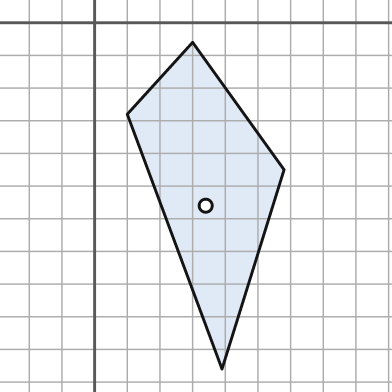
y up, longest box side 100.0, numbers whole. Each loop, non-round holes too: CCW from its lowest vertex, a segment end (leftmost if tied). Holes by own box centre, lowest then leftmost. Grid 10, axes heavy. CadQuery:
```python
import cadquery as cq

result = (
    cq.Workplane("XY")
    .moveTo(39.0, -106.0)
    .lineTo(58.0, -45.0)
    .lineTo(30.0, -6.0)
    .lineTo(10.0, -28.0)
    .close()
    .moveTo(34.0, -56.0)
    .circle(2.0)
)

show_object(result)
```